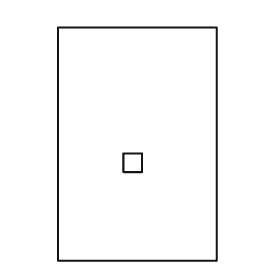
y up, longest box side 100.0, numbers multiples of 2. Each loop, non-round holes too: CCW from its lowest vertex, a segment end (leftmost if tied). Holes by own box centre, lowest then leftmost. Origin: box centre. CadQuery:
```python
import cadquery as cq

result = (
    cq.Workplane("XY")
    .moveTo(-34.0, -50.0)
    .lineTo(34.0, -50.0)
    .lineTo(34.0, 50.0)
    .lineTo(-34.0, 50.0)
    .close()
    .moveTo(-6.0, -12.0)
    .lineTo(2.0, -12.0)
    .lineTo(2.0, -4.0)
    .lineTo(-6.0, -4.0)
    .close()
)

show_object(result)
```